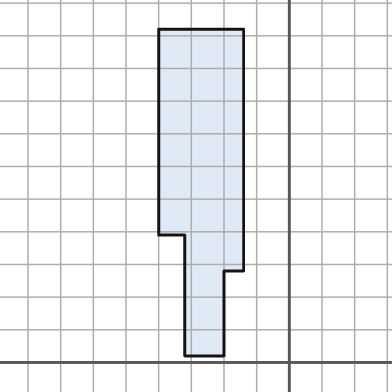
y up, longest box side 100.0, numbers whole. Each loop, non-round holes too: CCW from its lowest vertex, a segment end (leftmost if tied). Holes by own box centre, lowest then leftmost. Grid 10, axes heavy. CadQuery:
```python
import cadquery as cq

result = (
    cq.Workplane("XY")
    .moveTo(-32.0, 2.0)
    .lineTo(-20.0, 2.0)
    .lineTo(-20.0, 28.0)
    .lineTo(-14.0, 28.0)
    .lineTo(-14.0, 102.0)
    .lineTo(-40.0, 102.0)
    .lineTo(-40.0, 39.0)
    .lineTo(-32.0, 39.0)
    .close()
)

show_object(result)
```